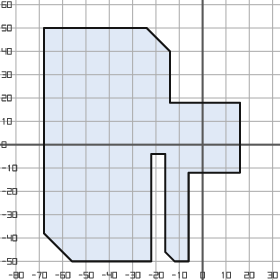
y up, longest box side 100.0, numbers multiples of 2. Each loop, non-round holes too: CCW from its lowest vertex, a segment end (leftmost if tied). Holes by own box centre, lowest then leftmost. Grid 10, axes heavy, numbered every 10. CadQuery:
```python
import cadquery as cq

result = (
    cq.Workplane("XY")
    .moveTo(-56.0, -50.0)
    .lineTo(-22.0, -50.0)
    .lineTo(-22.0, -4.0)
    .lineTo(-16.0, -4.0)
    .lineTo(-16.0, -46.0)
    .lineTo(-12.0, -50.0)
    .lineTo(-6.0, -50.0)
    .lineTo(-6.0, -12.0)
    .lineTo(16.0, -12.0)
    .lineTo(16.0, 18.0)
    .lineTo(-14.0, 18.0)
    .lineTo(-14.0, 40.0)
    .lineTo(-24.0, 50.0)
    .lineTo(-68.0, 50.0)
    .lineTo(-68.0, -38.0)
    .close()
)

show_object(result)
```